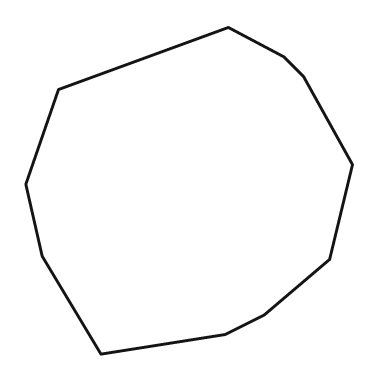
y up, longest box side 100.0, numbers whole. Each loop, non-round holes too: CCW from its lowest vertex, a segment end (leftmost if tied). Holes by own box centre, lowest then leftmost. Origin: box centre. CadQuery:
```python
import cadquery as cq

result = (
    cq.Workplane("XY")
    .moveTo(-27.0, -50.0)
    .lineTo(11.0, -44.0)
    .lineTo(23.0, -38.0)
    .lineTo(43.0, -21.0)
    .lineTo(50.0, 8.0)
    .lineTo(35.0, 35.0)
    .lineTo(29.0, 41.0)
    .lineTo(12.0, 50.0)
    .lineTo(-40.0, 31.0)
    .lineTo(-50.0, 2.0)
    .lineTo(-45.0, -20.0)
    .close()
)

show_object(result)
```